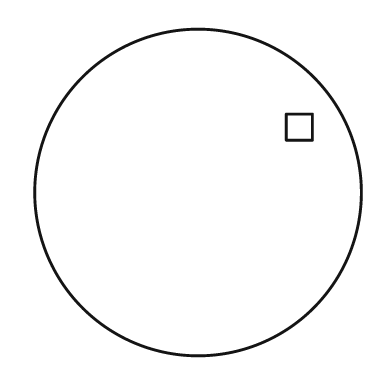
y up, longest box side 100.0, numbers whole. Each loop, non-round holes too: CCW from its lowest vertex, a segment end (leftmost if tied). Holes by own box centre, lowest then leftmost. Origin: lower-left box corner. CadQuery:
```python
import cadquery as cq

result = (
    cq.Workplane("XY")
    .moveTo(50.0, 50.0)
    .circle(50.0)
    .moveTo(77.0, 66.0)
    .lineTo(85.0, 66.0)
    .lineTo(85.0, 74.0)
    .lineTo(77.0, 74.0)
    .close()
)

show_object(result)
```